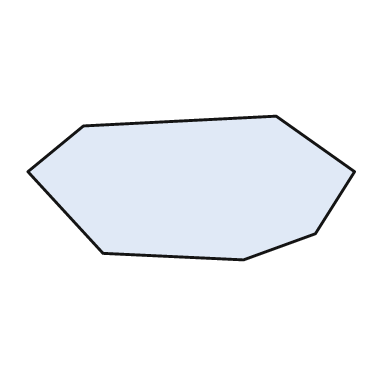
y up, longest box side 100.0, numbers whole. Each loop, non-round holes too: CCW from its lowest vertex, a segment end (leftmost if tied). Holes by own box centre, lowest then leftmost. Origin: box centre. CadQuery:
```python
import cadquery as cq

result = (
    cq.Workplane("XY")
    .moveTo(16.0, -22.0)
    .lineTo(38.0, -14.0)
    .lineTo(50.0, 5.0)
    .lineTo(26.0, 22.0)
    .lineTo(-33.0, 19.0)
    .lineTo(-50.0, 5.0)
    .lineTo(-27.0, -20.0)
    .close()
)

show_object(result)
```